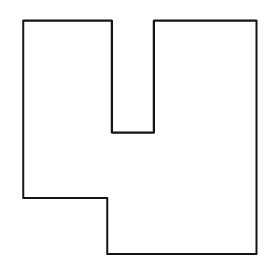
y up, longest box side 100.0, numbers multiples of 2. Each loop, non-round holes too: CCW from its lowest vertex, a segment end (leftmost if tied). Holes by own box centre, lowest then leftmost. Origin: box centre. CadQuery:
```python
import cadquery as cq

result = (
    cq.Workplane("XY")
    .moveTo(-14.0, -50.0)
    .lineTo(50.0, -50.0)
    .lineTo(50.0, 50.0)
    .lineTo(6.0, 50.0)
    .lineTo(6.0, 2.0)
    .lineTo(-12.0, 2.0)
    .lineTo(-12.0, 50.0)
    .lineTo(-50.0, 50.0)
    .lineTo(-50.0, -26.0)
    .lineTo(-14.0, -26.0)
    .close()
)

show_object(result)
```